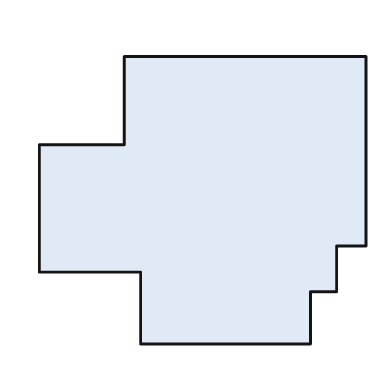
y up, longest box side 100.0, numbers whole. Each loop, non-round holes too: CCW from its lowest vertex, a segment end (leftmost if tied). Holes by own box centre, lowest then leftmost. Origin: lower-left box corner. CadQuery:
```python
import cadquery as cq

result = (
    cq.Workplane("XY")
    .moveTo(31.0, 0.0)
    .lineTo(83.0, 0.0)
    .lineTo(83.0, 16.0)
    .lineTo(91.0, 16.0)
    .lineTo(91.0, 30.0)
    .lineTo(100.0, 30.0)
    .lineTo(100.0, 88.0)
    .lineTo(26.0, 88.0)
    .lineTo(26.0, 61.0)
    .lineTo(0.0, 61.0)
    .lineTo(0.0, 22.0)
    .lineTo(31.0, 22.0)
    .close()
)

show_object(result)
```